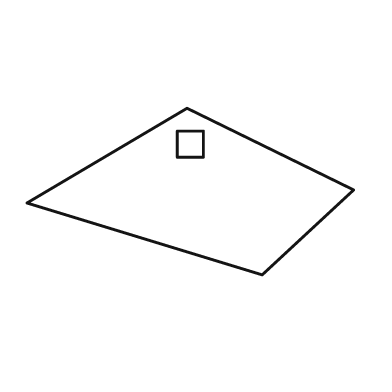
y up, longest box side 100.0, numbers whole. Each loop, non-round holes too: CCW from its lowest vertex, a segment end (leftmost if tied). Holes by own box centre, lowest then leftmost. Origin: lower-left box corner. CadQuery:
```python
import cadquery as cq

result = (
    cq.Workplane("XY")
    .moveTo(72.0, 0.0)
    .lineTo(100.0, 26.0)
    .lineTo(49.0, 51.0)
    .lineTo(0.0, 22.0)
    .close()
    .moveTo(46.0, 36.0)
    .lineTo(54.0, 36.0)
    .lineTo(54.0, 44.0)
    .lineTo(46.0, 44.0)
    .close()
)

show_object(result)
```